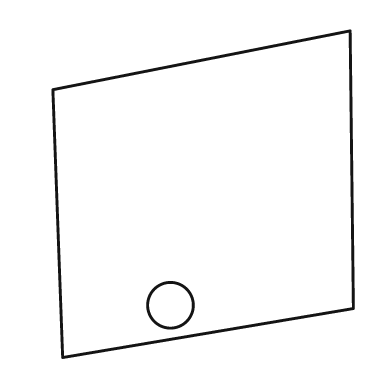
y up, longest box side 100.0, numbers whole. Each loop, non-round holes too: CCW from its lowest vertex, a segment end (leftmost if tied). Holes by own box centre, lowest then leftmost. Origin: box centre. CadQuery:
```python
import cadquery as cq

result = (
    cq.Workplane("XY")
    .moveTo(-43.0, -50.0)
    .lineTo(46.0, -35.0)
    .lineTo(45.0, 50.0)
    .lineTo(-46.0, 32.0)
    .close()
    .moveTo(-10.0, -34.0)
    .circle(7.0)
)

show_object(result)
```